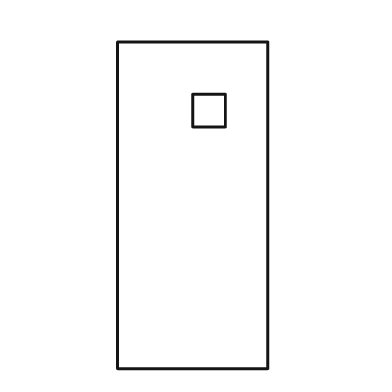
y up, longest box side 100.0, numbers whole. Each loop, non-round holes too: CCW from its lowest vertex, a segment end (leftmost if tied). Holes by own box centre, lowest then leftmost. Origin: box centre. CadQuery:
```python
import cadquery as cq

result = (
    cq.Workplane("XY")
    .moveTo(-23.0, -50.0)
    .lineTo(23.0, -50.0)
    .lineTo(23.0, 50.0)
    .lineTo(-23.0, 50.0)
    .close()
    .moveTo(0.0, 24.0)
    .lineTo(10.0, 24.0)
    .lineTo(10.0, 34.0)
    .lineTo(0.0, 34.0)
    .close()
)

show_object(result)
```